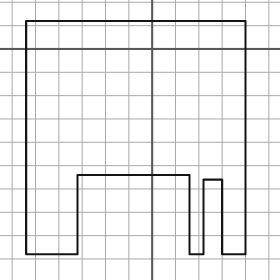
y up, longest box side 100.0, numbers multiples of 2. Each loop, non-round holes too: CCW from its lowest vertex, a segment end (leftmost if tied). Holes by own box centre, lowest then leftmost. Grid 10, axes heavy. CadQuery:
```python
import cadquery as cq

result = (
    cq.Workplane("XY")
    .moveTo(-54.0, -88.0)
    .lineTo(-32.0, -88.0)
    .lineTo(-32.0, -54.0)
    .lineTo(16.0, -54.0)
    .lineTo(16.0, -88.0)
    .lineTo(22.0, -88.0)
    .lineTo(22.0, -56.0)
    .lineTo(30.0, -56.0)
    .lineTo(30.0, -88.0)
    .lineTo(40.0, -88.0)
    .lineTo(40.0, 12.0)
    .lineTo(-54.0, 12.0)
    .close()
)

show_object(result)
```